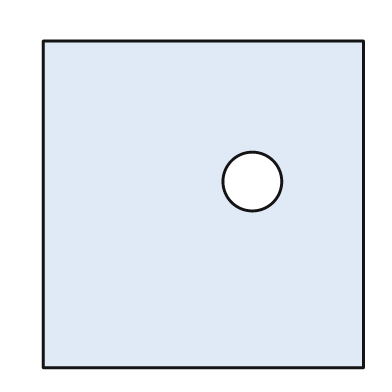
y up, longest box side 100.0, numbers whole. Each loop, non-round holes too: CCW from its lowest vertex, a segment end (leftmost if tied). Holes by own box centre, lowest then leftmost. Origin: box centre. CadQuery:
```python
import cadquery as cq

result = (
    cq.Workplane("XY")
    .moveTo(-49.0, -50.0)
    .lineTo(49.0, -50.0)
    .lineTo(49.0, 50.0)
    .lineTo(-49.0, 50.0)
    .close()
    .moveTo(15.0, 7.0)
    .circle(9.0)
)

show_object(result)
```